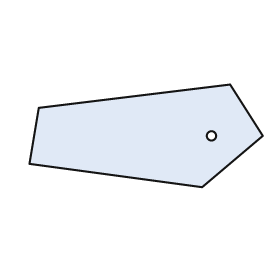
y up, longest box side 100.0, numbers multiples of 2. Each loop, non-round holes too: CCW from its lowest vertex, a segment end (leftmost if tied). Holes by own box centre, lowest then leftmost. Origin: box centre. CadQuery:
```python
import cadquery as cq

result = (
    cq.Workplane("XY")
    .moveTo(24.0, -22.0)
    .lineTo(50.0, 0.0)
    .lineTo(36.0, 22.0)
    .lineTo(-46.0, 12.0)
    .lineTo(-50.0, -12.0)
    .close()
    .moveTo(28.0, 0.0)
    .circle(2.0)
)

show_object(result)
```